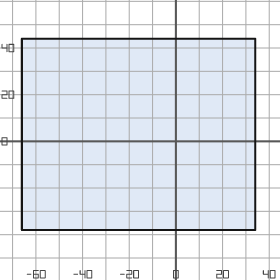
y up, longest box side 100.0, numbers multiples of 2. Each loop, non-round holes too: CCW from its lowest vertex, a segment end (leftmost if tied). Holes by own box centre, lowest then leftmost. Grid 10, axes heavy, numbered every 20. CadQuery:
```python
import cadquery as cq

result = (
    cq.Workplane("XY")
    .moveTo(-66.0, -38.0)
    .lineTo(34.0, -38.0)
    .lineTo(34.0, 44.0)
    .lineTo(-66.0, 44.0)
    .close()
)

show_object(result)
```